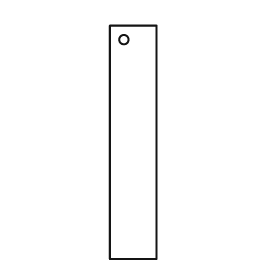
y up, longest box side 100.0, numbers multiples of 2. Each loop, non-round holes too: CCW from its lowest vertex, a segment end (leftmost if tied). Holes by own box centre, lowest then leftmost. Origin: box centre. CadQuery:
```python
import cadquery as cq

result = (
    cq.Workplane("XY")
    .moveTo(-10.0, -50.0)
    .lineTo(10.0, -50.0)
    .lineTo(10.0, 50.0)
    .lineTo(-10.0, 50.0)
    .close()
    .moveTo(-4.0, 44.0)
    .circle(2.0)
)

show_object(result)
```